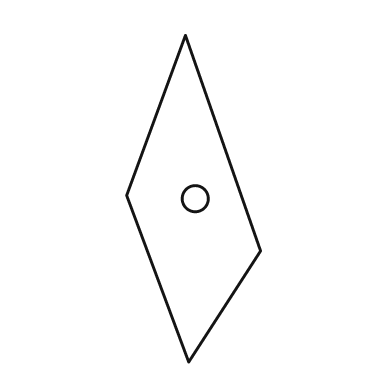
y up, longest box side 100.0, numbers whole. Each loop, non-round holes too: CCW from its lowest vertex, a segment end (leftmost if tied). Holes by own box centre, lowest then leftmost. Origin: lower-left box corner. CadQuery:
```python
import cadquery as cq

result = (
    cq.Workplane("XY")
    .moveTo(19.0, 0.0)
    .lineTo(41.0, 34.0)
    .lineTo(18.0, 100.0)
    .lineTo(0.0, 51.0)
    .close()
    .moveTo(21.0, 50.0)
    .circle(4.0)
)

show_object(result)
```